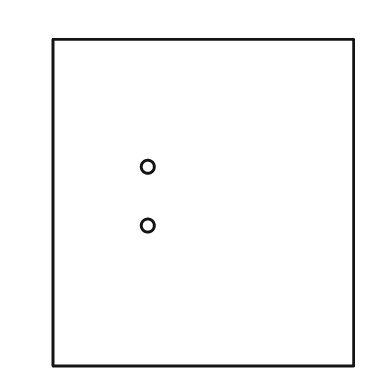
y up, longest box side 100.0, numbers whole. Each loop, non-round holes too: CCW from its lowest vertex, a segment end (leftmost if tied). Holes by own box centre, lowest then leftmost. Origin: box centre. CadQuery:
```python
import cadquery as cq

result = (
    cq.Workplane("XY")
    .moveTo(-46.0, -50.0)
    .lineTo(46.0, -50.0)
    .lineTo(46.0, 50.0)
    .lineTo(-46.0, 50.0)
    .close()
    .moveTo(-17.0, -7.0)
    .circle(2.0)
    .moveTo(-17.0, 11.0)
    .circle(2.0)
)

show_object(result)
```